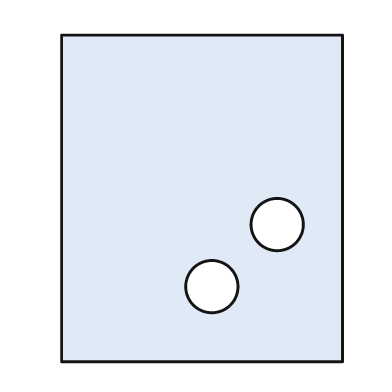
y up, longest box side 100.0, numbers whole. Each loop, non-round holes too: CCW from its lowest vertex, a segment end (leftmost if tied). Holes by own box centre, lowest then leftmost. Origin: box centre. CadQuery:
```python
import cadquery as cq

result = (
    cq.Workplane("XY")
    .moveTo(-43.0, -50.0)
    .lineTo(43.0, -50.0)
    .lineTo(43.0, 50.0)
    .lineTo(-43.0, 50.0)
    .close()
    .moveTo(3.0, -27.0)
    .circle(8.0)
    .moveTo(23.0, -8.0)
    .circle(8.0)
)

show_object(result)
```